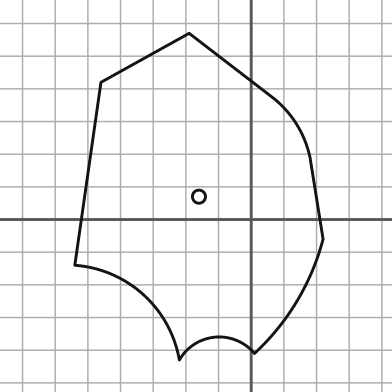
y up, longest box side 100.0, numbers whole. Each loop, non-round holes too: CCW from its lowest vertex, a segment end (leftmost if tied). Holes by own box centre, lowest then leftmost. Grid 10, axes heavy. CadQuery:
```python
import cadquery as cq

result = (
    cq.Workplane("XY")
    .moveTo(-22.0, -43.0)
    .threePointArc((-11.0, -36.0), (1.0, -41.0))
    .threePointArc((14.0, -25.0), (22.0, -6.0))
    .lineTo(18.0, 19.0)
    .threePointArc((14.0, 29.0), (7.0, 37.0))
    .lineTo(-19.0, 57.0)
    .lineTo(-46.0, 42.0)
    .lineTo(-54.0, -14.0)
    .threePointArc((-33.0, -23.0), (-22.0, -43.0))
    .close()
    .moveTo(-16.0, 7.0)
    .circle(2.0)
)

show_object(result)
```